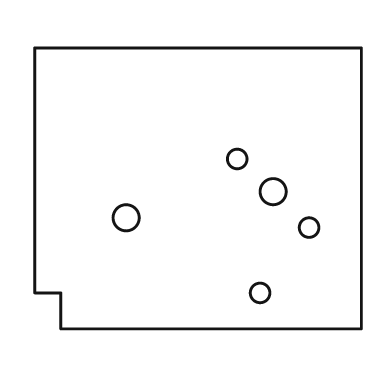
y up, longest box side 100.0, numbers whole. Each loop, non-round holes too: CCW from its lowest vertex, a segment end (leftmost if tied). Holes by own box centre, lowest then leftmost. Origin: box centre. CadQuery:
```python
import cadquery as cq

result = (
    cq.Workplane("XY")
    .moveTo(-42.0, -43.0)
    .lineTo(50.0, -43.0)
    .lineTo(50.0, 43.0)
    .lineTo(-50.0, 43.0)
    .lineTo(-50.0, -32.0)
    .lineTo(-42.0, -32.0)
    .close()
    .moveTo(19.0, -32.0)
    .circle(3.0)
    .moveTo(34.0, -12.0)
    .circle(3.0)
    .moveTo(-22.0, -9.0)
    .circle(4.0)
    .moveTo(23.0, -1.0)
    .circle(4.0)
    .moveTo(12.0, 9.0)
    .circle(3.0)
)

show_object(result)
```